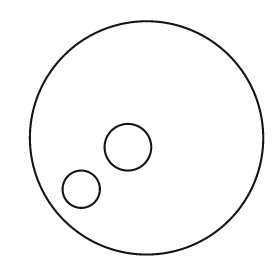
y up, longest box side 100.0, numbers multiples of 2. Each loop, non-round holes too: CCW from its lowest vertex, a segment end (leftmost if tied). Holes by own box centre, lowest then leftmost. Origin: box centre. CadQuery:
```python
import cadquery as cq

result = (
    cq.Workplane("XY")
    .moveTo(0.0, 0.0)
    .circle(50.0)
    .moveTo(-28.0, -22.0)
    .circle(8.0)
    .moveTo(-8.0, -4.0)
    .circle(10.0)
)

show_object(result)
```